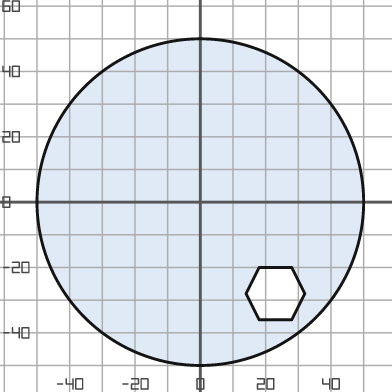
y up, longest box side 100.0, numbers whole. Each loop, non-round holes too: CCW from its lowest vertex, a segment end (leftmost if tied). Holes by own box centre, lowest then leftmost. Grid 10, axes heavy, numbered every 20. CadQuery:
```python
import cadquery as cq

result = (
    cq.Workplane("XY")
    .moveTo(0.0, 0.0)
    .circle(50.0)
    .moveTo(18.0, -36.0)
    .lineTo(28.0, -36.0)
    .lineTo(32.0, -28.0)
    .lineTo(28.0, -20.0)
    .lineTo(18.0, -20.0)
    .lineTo(14.0, -28.0)
    .close()
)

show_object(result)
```